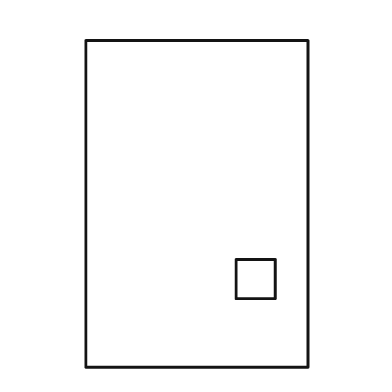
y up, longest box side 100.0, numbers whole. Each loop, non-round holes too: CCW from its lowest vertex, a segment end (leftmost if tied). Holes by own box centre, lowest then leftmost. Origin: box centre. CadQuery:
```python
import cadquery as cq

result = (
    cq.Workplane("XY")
    .moveTo(-34.0, -50.0)
    .lineTo(34.0, -50.0)
    .lineTo(34.0, 50.0)
    .lineTo(-34.0, 50.0)
    .close()
    .moveTo(12.0, -29.0)
    .lineTo(24.0, -29.0)
    .lineTo(24.0, -17.0)
    .lineTo(12.0, -17.0)
    .close()
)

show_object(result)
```